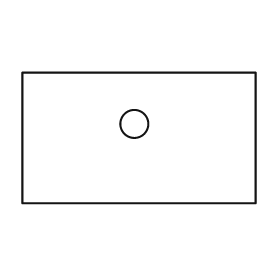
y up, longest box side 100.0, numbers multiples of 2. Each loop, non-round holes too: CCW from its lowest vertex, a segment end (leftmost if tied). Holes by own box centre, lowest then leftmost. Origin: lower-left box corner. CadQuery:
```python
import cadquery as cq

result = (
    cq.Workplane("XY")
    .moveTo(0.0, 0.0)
    .lineTo(100.0, 0.0)
    .lineTo(100.0, 56.0)
    .lineTo(0.0, 56.0)
    .close()
    .moveTo(48.0, 34.0)
    .circle(6.0)
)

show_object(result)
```